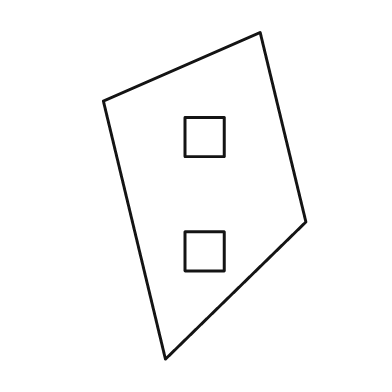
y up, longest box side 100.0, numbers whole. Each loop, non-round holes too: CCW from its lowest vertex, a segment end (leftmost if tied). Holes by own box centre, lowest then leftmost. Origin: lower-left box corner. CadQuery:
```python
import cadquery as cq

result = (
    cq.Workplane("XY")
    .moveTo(19.0, 0.0)
    .lineTo(62.0, 42.0)
    .lineTo(48.0, 100.0)
    .lineTo(0.0, 79.0)
    .close()
    .moveTo(25.0, 27.0)
    .lineTo(37.0, 27.0)
    .lineTo(37.0, 39.0)
    .lineTo(25.0, 39.0)
    .close()
    .moveTo(25.0, 62.0)
    .lineTo(37.0, 62.0)
    .lineTo(37.0, 74.0)
    .lineTo(25.0, 74.0)
    .close()
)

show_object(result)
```